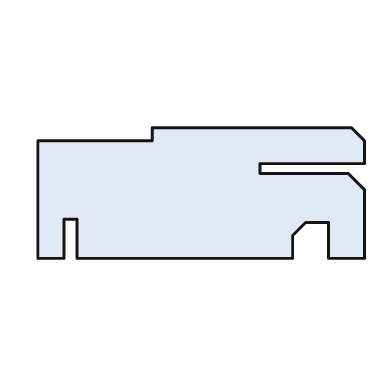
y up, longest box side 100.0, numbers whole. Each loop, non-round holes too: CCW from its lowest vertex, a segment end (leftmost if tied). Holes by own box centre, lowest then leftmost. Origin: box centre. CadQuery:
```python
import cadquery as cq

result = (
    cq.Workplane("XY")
    .moveTo(-50.0, -20.0)
    .lineTo(-42.0, -20.0)
    .lineTo(-42.0, -8.0)
    .lineTo(-38.0, -8.0)
    .lineTo(-38.0, -20.0)
    .lineTo(28.0, -20.0)
    .lineTo(28.0, -13.0)
    .lineTo(32.0, -9.0)
    .lineTo(39.0, -9.0)
    .lineTo(39.0, -20.0)
    .lineTo(50.0, -20.0)
    .lineTo(50.0, 1.0)
    .lineTo(45.0, 6.0)
    .lineTo(18.0, 6.0)
    .lineTo(18.0, 9.0)
    .lineTo(50.0, 9.0)
    .lineTo(50.0, 16.0)
    .lineTo(46.0, 20.0)
    .lineTo(-15.0, 20.0)
    .lineTo(-15.0, 16.0)
    .lineTo(-50.0, 16.0)
    .close()
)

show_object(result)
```